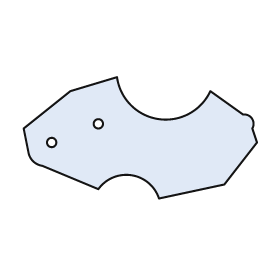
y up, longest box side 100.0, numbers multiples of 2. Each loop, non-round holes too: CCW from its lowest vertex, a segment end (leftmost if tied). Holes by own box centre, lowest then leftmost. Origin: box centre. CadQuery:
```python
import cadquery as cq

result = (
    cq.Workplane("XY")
    .moveTo(8.0, -26.0)
    .lineTo(36.0, -20.0)
    .lineTo(50.0, -2.0)
    .lineTo(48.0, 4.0)
    .threePointArc((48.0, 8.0), (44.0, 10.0))
    .lineTo(30.0, 20.0)
    .threePointArc((8.0, 8.0), (-10.0, 26.0))
    .lineTo(-30.0, 20.0)
    .lineTo(-50.0, 4.0)
    .lineTo(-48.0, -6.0)
    .threePointArc((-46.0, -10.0), (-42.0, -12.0))
    .lineTo(-18.0, -22.0)
    .threePointArc((-4.0, -16.0), (8.0, -26.0))
    .close()
    .moveTo(-38.0, -2.0)
    .circle(2.0)
    .moveTo(-18.0, 6.0)
    .circle(2.0)
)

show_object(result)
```